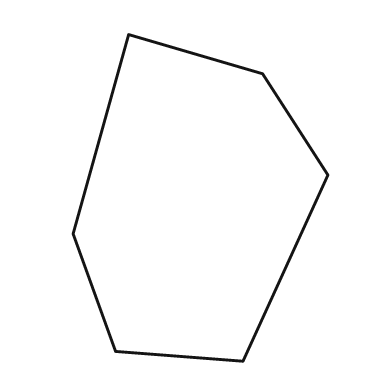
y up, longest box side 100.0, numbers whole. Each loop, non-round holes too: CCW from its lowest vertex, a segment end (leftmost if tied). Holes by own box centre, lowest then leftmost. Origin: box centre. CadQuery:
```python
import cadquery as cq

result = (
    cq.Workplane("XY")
    .moveTo(13.0, -50.0)
    .lineTo(39.0, 7.0)
    .lineTo(19.0, 38.0)
    .lineTo(-22.0, 50.0)
    .lineTo(-39.0, -11.0)
    .lineTo(-26.0, -47.0)
    .close()
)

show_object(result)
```